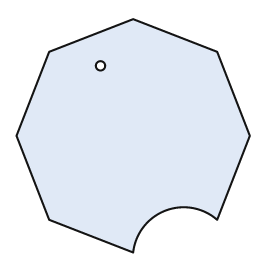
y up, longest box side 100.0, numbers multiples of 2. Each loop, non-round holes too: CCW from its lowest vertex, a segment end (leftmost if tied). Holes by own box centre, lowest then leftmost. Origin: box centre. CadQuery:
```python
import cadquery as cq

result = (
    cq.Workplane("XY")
    .moveTo(0.0, -50.0)
    .threePointArc((14.0, -32.0), (36.0, -36.0))
    .lineTo(50.0, 0.0)
    .lineTo(36.0, 36.0)
    .lineTo(0.0, 50.0)
    .lineTo(-36.0, 36.0)
    .lineTo(-50.0, 0.0)
    .lineTo(-36.0, -36.0)
    .close()
    .moveTo(-14.0, 30.0)
    .circle(2.0)
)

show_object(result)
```